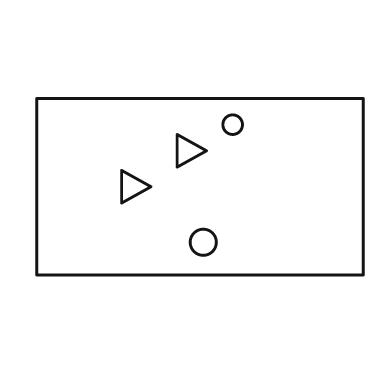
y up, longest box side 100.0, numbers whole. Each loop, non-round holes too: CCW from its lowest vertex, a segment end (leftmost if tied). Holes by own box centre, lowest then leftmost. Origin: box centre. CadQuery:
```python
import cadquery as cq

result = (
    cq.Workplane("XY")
    .moveTo(-50.0, -27.0)
    .lineTo(50.0, -27.0)
    .lineTo(50.0, 27.0)
    .lineTo(-50.0, 27.0)
    .close()
    .moveTo(1.0, -17.0)
    .circle(4.0)
    .moveTo(-24.0, -5.0)
    .lineTo(-15.0, 0.0)
    .lineTo(-24.0, 5.0)
    .close()
    .moveTo(-7.0, 6.0)
    .lineTo(2.0, 11.0)
    .lineTo(-7.0, 16.0)
    .close()
    .moveTo(10.0, 19.0)
    .circle(3.0)
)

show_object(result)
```